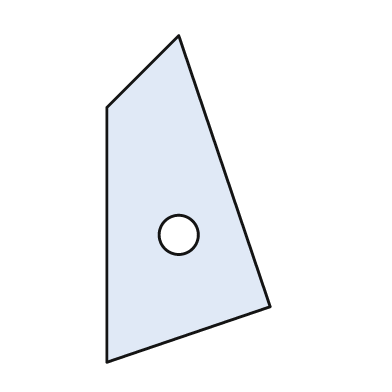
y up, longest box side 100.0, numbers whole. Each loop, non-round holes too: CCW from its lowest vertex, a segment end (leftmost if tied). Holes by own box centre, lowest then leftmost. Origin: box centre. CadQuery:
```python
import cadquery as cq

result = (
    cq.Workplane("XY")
    .moveTo(-25.0, -50.0)
    .lineTo(25.0, -33.0)
    .lineTo(-3.0, 50.0)
    .lineTo(-25.0, 28.0)
    .close()
    .moveTo(-3.0, -11.0)
    .circle(6.0)
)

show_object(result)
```